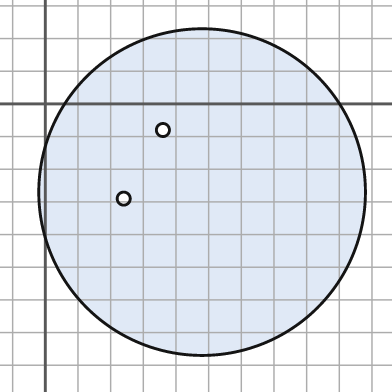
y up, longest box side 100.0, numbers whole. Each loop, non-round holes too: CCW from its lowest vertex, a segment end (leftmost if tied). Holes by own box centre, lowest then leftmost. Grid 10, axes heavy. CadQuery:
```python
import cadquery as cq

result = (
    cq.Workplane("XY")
    .moveTo(48.0, -27.0)
    .circle(50.0)
    .moveTo(24.0, -29.0)
    .circle(2.0)
    .moveTo(36.0, -8.0)
    .circle(2.0)
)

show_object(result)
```